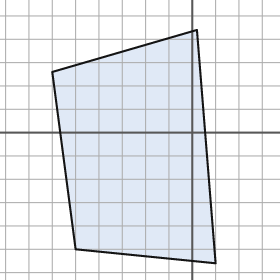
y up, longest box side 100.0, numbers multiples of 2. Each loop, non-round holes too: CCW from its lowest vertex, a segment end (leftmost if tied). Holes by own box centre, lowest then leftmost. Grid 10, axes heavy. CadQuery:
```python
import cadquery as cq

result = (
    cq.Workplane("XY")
    .moveTo(10.0, -56.0)
    .lineTo(2.0, 44.0)
    .lineTo(-60.0, 26.0)
    .lineTo(-50.0, -50.0)
    .close()
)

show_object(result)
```